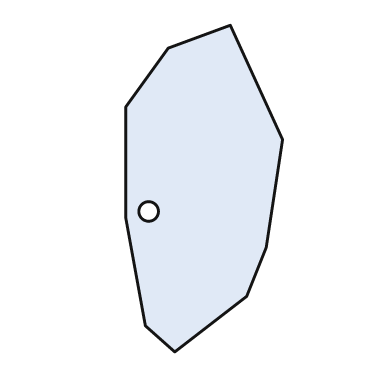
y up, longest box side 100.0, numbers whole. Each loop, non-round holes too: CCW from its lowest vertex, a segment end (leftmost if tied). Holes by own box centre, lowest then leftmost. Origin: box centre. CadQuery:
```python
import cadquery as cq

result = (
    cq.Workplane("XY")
    .moveTo(-9.0, -50.0)
    .lineTo(13.0, -33.0)
    .lineTo(19.0, -18.0)
    .lineTo(24.0, 15.0)
    .lineTo(8.0, 50.0)
    .lineTo(-11.0, 43.0)
    .lineTo(-24.0, 25.0)
    .lineTo(-24.0, -9.0)
    .lineTo(-18.0, -42.0)
    .close()
    .moveTo(-17.0, -7.0)
    .circle(3.0)
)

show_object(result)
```